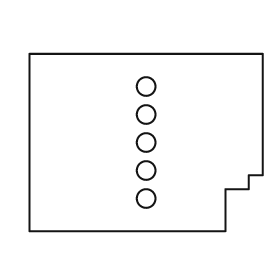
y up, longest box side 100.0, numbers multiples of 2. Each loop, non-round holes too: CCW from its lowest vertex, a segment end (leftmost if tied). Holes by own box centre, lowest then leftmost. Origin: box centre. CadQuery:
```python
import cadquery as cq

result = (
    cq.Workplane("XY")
    .moveTo(-50.0, -38.0)
    .lineTo(34.0, -38.0)
    .lineTo(34.0, -20.0)
    .lineTo(44.0, -20.0)
    .lineTo(44.0, -14.0)
    .lineTo(50.0, -14.0)
    .lineTo(50.0, 38.0)
    .lineTo(-50.0, 38.0)
    .close()
    .moveTo(0.0, -24.0)
    .circle(4.0)
    .moveTo(0.0, -12.0)
    .circle(4.0)
    .moveTo(0.0, 0.0)
    .circle(4.0)
    .moveTo(0.0, 12.0)
    .circle(4.0)
    .moveTo(0.0, 24.0)
    .circle(4.0)
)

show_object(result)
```